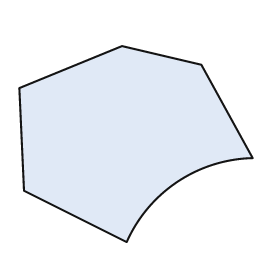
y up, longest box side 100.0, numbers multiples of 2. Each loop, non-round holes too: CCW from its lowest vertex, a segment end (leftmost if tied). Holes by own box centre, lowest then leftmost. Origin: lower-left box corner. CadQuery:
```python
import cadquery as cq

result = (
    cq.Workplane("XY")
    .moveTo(46.0, 0.0)
    .threePointArc((68.0, 26.0), (100.0, 36.0))
    .lineTo(78.0, 76.0)
    .lineTo(44.0, 84.0)
    .lineTo(0.0, 66.0)
    .lineTo(2.0, 22.0)
    .close()
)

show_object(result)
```